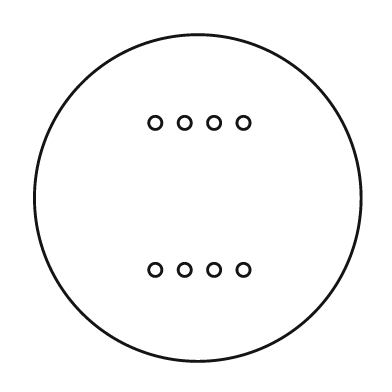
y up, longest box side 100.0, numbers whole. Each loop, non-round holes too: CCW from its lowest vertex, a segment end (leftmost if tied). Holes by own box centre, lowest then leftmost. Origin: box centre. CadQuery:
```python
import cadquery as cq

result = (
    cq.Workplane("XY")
    .moveTo(0.0, 0.0)
    .circle(50.0)
    .moveTo(-13.0, -22.0)
    .circle(2.0)
    .moveTo(-4.0, -22.0)
    .circle(2.0)
    .moveTo(5.0, -22.0)
    .circle(2.0)
    .moveTo(14.0, -22.0)
    .circle(2.0)
    .moveTo(-13.0, 23.0)
    .circle(2.0)
    .moveTo(-4.0, 23.0)
    .circle(2.0)
    .moveTo(5.0, 23.0)
    .circle(2.0)
    .moveTo(14.0, 23.0)
    .circle(2.0)
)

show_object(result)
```